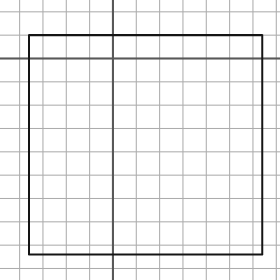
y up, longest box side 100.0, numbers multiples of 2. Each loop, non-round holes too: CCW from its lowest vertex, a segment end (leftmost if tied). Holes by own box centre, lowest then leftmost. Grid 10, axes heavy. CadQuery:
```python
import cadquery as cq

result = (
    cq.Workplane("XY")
    .moveTo(-36.0, -84.0)
    .lineTo(64.0, -84.0)
    .lineTo(64.0, 10.0)
    .lineTo(-36.0, 10.0)
    .close()
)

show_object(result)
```